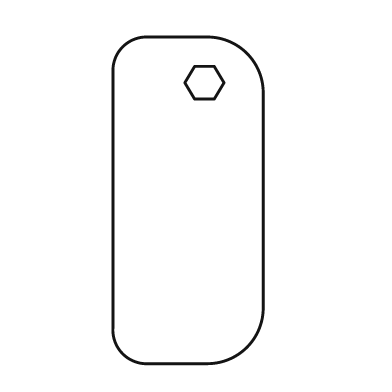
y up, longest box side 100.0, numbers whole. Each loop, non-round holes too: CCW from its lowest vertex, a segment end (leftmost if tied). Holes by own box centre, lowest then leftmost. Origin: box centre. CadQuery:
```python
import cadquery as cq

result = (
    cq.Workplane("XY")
    .moveTo(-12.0, -50.0)
    .lineTo(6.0, -50.0)
    .threePointArc((18.0, -45.0), (23.0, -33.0))
    .lineTo(23.0, 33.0)
    .threePointArc((18.0, 45.0), (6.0, 50.0))
    .lineTo(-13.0, 50.0)
    .threePointArc((-20.0, 47.0), (-23.0, 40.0))
    .lineTo(-23.0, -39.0)
    .threePointArc((-20.0, -47.0), (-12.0, -50.0))
    .close()
    .moveTo(2.0, 31.0)
    .lineTo(8.0, 31.0)
    .lineTo(11.0, 36.0)
    .lineTo(8.0, 41.0)
    .lineTo(2.0, 41.0)
    .lineTo(-1.0, 36.0)
    .close()
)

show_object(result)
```